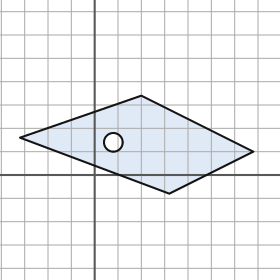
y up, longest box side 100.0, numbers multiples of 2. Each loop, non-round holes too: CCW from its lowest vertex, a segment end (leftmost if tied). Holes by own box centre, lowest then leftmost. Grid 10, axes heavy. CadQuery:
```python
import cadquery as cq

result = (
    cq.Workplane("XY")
    .moveTo(32.0, -8.0)
    .lineTo(68.0, 10.0)
    .lineTo(20.0, 34.0)
    .lineTo(-32.0, 16.0)
    .close()
    .moveTo(8.0, 14.0)
    .circle(4.0)
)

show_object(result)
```